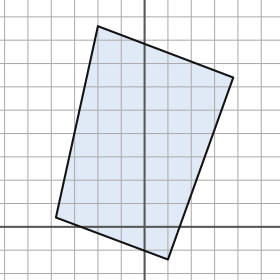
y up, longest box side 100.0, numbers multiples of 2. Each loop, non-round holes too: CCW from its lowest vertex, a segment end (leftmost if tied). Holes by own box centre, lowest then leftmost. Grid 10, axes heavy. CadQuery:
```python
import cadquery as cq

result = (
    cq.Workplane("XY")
    .moveTo(10.0, -14.0)
    .lineTo(38.0, 64.0)
    .lineTo(-20.0, 86.0)
    .lineTo(-38.0, 4.0)
    .close()
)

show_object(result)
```